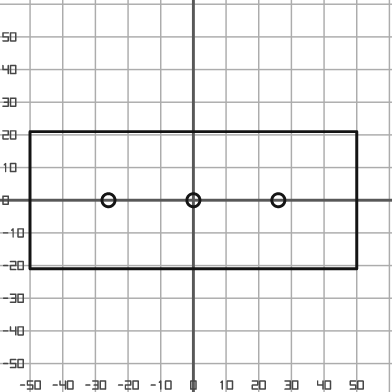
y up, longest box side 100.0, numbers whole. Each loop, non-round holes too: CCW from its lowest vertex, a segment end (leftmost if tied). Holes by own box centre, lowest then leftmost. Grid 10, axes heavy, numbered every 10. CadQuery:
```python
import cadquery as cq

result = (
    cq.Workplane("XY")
    .moveTo(-50.0, -21.0)
    .lineTo(50.0, -21.0)
    .lineTo(50.0, 21.0)
    .lineTo(-50.0, 21.0)
    .close()
    .moveTo(-26.0, 0.0)
    .circle(2.0)
    .moveTo(0.0, 0.0)
    .circle(2.0)
    .moveTo(26.0, 0.0)
    .circle(2.0)
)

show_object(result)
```